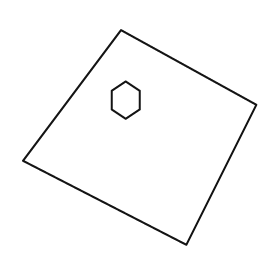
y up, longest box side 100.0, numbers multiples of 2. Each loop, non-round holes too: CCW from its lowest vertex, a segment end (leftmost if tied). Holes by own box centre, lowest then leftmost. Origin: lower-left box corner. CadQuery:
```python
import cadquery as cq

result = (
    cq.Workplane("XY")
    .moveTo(70.0, 0.0)
    .lineTo(100.0, 60.0)
    .lineTo(42.0, 92.0)
    .lineTo(0.0, 36.0)
    .close()
    .moveTo(44.0, 54.0)
    .lineTo(50.0, 58.0)
    .lineTo(50.0, 66.0)
    .lineTo(44.0, 70.0)
    .lineTo(38.0, 66.0)
    .lineTo(38.0, 58.0)
    .close()
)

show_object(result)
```